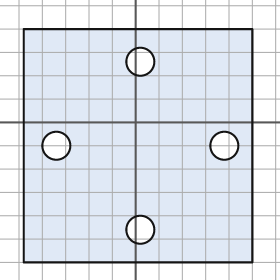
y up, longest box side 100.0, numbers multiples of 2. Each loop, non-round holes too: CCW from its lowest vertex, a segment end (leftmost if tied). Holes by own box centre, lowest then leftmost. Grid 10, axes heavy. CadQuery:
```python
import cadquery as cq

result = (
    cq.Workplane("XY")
    .moveTo(-48.0, -60.0)
    .lineTo(50.0, -60.0)
    .lineTo(50.0, 40.0)
    .lineTo(-48.0, 40.0)
    .close()
    .moveTo(2.0, -46.0)
    .circle(6.0)
    .moveTo(-34.0, -10.0)
    .circle(6.0)
    .moveTo(38.0, -10.0)
    .circle(6.0)
    .moveTo(2.0, 26.0)
    .circle(6.0)
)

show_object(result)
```